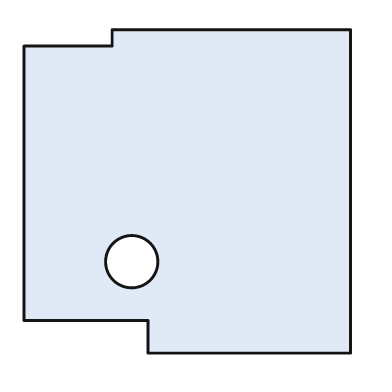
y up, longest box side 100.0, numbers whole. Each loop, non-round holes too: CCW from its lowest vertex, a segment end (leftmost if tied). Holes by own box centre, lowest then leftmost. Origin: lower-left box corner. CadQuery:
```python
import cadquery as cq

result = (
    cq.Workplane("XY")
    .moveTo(38.0, 0.0)
    .lineTo(100.0, 0.0)
    .lineTo(100.0, 99.0)
    .lineTo(27.0, 99.0)
    .lineTo(27.0, 94.0)
    .lineTo(0.0, 94.0)
    .lineTo(0.0, 10.0)
    .lineTo(38.0, 10.0)
    .close()
    .moveTo(33.0, 28.0)
    .circle(8.0)
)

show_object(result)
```